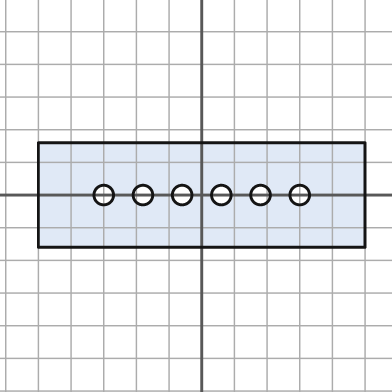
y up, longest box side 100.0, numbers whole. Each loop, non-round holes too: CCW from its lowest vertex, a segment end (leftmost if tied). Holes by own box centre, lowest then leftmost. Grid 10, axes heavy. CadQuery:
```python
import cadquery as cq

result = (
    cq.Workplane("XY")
    .moveTo(-50.0, -16.0)
    .lineTo(50.0, -16.0)
    .lineTo(50.0, 16.0)
    .lineTo(-50.0, 16.0)
    .close()
    .moveTo(-30.0, 0.0)
    .circle(3.0)
    .moveTo(-18.0, 0.0)
    .circle(3.0)
    .moveTo(-6.0, 0.0)
    .circle(3.0)
    .moveTo(6.0, 0.0)
    .circle(3.0)
    .moveTo(18.0, 0.0)
    .circle(3.0)
    .moveTo(30.0, 0.0)
    .circle(3.0)
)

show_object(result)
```